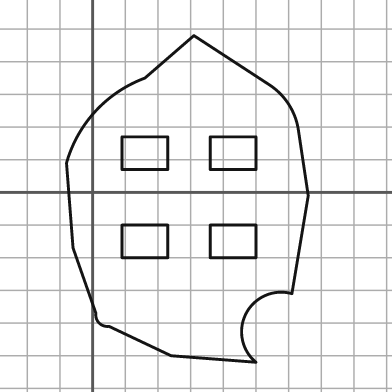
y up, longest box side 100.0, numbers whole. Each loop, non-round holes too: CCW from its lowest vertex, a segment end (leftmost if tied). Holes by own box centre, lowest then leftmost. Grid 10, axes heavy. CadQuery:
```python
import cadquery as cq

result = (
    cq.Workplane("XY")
    .moveTo(50.0, -52.0)
    .threePointArc((47.0, -37.0), (61.0, -31.0))
    .lineTo(66.0, -1.0)
    .lineTo(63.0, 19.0)
    .threePointArc((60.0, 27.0), (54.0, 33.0))
    .lineTo(31.0, 48.0)
    .lineTo(16.0, 35.0)
    .threePointArc((1.0, 25.0), (-8.0, 9.0))
    .lineTo(-6.0, -17.0)
    .lineTo(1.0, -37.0)
    .threePointArc((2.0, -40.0), (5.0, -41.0))
    .lineTo(24.0, -50.0)
    .close()
    .moveTo(9.0, -20.0)
    .lineTo(23.0, -20.0)
    .lineTo(23.0, -10.0)
    .lineTo(9.0, -10.0)
    .close()
    .moveTo(36.0, -20.0)
    .lineTo(50.0, -20.0)
    .lineTo(50.0, -10.0)
    .lineTo(36.0, -10.0)
    .close()
    .moveTo(9.0, 7.0)
    .lineTo(23.0, 7.0)
    .lineTo(23.0, 17.0)
    .lineTo(9.0, 17.0)
    .close()
    .moveTo(36.0, 7.0)
    .lineTo(50.0, 7.0)
    .lineTo(50.0, 17.0)
    .lineTo(36.0, 17.0)
    .close()
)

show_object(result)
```